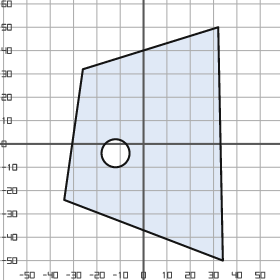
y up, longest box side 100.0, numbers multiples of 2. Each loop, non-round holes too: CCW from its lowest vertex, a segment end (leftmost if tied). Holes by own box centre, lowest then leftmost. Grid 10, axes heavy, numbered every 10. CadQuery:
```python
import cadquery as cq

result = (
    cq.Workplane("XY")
    .moveTo(34.0, -50.0)
    .lineTo(32.0, 50.0)
    .lineTo(-26.0, 32.0)
    .lineTo(-34.0, -24.0)
    .close()
    .moveTo(-12.0, -4.0)
    .circle(6.0)
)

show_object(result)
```